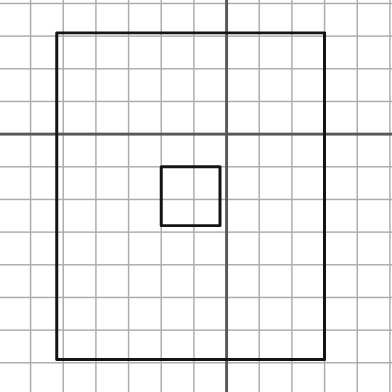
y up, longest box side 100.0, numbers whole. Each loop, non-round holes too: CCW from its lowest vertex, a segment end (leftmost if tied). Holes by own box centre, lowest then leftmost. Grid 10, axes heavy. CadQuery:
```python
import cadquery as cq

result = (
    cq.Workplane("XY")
    .moveTo(-52.0, -69.0)
    .lineTo(30.0, -69.0)
    .lineTo(30.0, 31.0)
    .lineTo(-52.0, 31.0)
    .close()
    .moveTo(-20.0, -28.0)
    .lineTo(-2.0, -28.0)
    .lineTo(-2.0, -10.0)
    .lineTo(-20.0, -10.0)
    .close()
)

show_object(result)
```